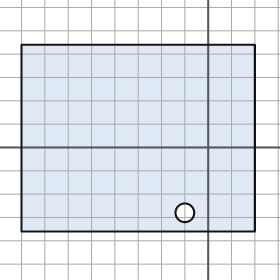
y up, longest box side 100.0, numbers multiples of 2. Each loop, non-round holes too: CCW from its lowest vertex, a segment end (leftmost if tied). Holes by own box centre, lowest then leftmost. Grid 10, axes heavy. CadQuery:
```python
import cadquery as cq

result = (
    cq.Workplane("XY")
    .moveTo(-80.0, -36.0)
    .lineTo(20.0, -36.0)
    .lineTo(20.0, 44.0)
    .lineTo(-80.0, 44.0)
    .close()
    .moveTo(-10.0, -28.0)
    .circle(4.0)
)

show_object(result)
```